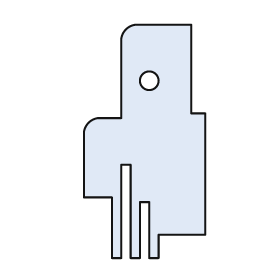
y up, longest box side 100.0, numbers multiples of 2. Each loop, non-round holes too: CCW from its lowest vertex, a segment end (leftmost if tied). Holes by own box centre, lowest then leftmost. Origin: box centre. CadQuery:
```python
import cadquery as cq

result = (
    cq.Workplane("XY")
    .moveTo(-14.0, -50.0)
    .lineTo(-10.0, -50.0)
    .lineTo(-10.0, -10.0)
    .lineTo(-6.0, -10.0)
    .lineTo(-6.0, -50.0)
    .lineTo(-2.0, -50.0)
    .lineTo(-2.0, -26.0)
    .lineTo(2.0, -26.0)
    .lineTo(2.0, -50.0)
    .lineTo(6.0, -50.0)
    .lineTo(6.0, -40.0)
    .lineTo(26.0, -40.0)
    .lineTo(26.0, 12.0)
    .lineTo(20.0, 12.0)
    .lineTo(20.0, 50.0)
    .lineTo(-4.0, 50.0)
    .threePointArc((-8.0, 48.0), (-10.0, 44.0))
    .lineTo(-10.0, 10.0)
    .lineTo(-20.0, 10.0)
    .threePointArc((-24.0, 8.0), (-26.0, 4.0))
    .lineTo(-26.0, -24.0)
    .lineTo(-14.0, -24.0)
    .close()
    .moveTo(2.0, 26.0)
    .circle(4.0)
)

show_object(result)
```